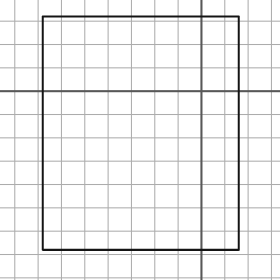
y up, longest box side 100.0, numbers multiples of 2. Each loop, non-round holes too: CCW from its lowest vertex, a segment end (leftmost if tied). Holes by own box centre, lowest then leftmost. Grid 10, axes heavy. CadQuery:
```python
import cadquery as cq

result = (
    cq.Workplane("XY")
    .moveTo(-68.0, -68.0)
    .lineTo(16.0, -68.0)
    .lineTo(16.0, 32.0)
    .lineTo(-68.0, 32.0)
    .close()
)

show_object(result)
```